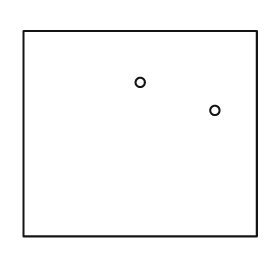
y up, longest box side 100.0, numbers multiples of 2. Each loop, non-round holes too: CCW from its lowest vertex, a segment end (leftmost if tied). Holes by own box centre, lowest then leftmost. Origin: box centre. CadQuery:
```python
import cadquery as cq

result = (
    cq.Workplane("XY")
    .moveTo(-50.0, -44.0)
    .lineTo(50.0, -44.0)
    .lineTo(50.0, 44.0)
    .lineTo(-50.0, 44.0)
    .close()
    .moveTo(32.0, 10.0)
    .circle(2.0)
    .moveTo(0.0, 22.0)
    .circle(2.0)
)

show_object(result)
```